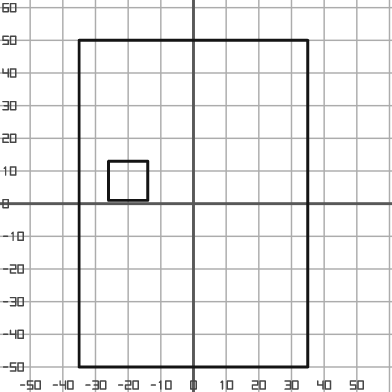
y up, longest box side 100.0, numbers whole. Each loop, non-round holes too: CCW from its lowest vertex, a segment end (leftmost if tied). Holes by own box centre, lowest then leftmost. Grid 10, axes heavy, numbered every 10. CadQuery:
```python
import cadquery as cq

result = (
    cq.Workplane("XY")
    .moveTo(-35.0, -50.0)
    .lineTo(35.0, -50.0)
    .lineTo(35.0, 50.0)
    .lineTo(-35.0, 50.0)
    .close()
    .moveTo(-26.0, 1.0)
    .lineTo(-14.0, 1.0)
    .lineTo(-14.0, 13.0)
    .lineTo(-26.0, 13.0)
    .close()
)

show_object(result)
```